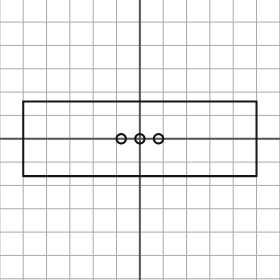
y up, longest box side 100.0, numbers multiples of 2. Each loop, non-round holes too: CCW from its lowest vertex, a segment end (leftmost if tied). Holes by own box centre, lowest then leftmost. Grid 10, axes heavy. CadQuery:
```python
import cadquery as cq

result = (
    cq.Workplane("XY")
    .moveTo(-50.0, -16.0)
    .lineTo(50.0, -16.0)
    .lineTo(50.0, 16.0)
    .lineTo(-50.0, 16.0)
    .close()
    .moveTo(-8.0, 0.0)
    .circle(2.0)
    .moveTo(0.0, 0.0)
    .circle(2.0)
    .moveTo(8.0, 0.0)
    .circle(2.0)
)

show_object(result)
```